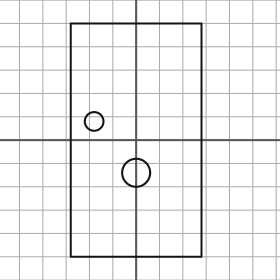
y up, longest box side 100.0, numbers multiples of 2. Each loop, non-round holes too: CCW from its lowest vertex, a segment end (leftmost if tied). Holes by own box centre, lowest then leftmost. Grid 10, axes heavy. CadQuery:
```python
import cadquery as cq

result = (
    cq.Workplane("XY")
    .moveTo(-28.0, -50.0)
    .lineTo(28.0, -50.0)
    .lineTo(28.0, 50.0)
    .lineTo(-28.0, 50.0)
    .close()
    .moveTo(0.0, -14.0)
    .circle(6.0)
    .moveTo(-18.0, 8.0)
    .circle(4.0)
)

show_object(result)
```